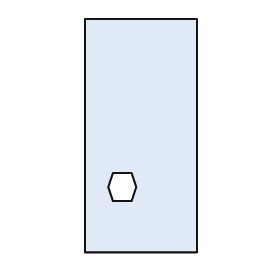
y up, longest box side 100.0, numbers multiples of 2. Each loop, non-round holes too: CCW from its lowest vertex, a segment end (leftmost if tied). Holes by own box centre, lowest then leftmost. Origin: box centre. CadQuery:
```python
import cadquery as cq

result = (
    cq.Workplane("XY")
    .moveTo(-24.0, -50.0)
    .lineTo(24.0, -50.0)
    .lineTo(24.0, 50.0)
    .lineTo(-24.0, 50.0)
    .close()
    .moveTo(-12.0, -28.0)
    .lineTo(-4.0, -28.0)
    .lineTo(-2.0, -22.0)
    .lineTo(-4.0, -16.0)
    .lineTo(-12.0, -16.0)
    .lineTo(-14.0, -22.0)
    .close()
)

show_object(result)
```